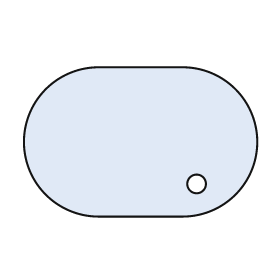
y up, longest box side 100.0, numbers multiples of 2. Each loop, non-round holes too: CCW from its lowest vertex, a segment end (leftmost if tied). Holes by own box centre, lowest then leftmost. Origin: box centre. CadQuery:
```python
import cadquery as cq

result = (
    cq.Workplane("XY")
    .moveTo(-18.0, -32.0)
    .lineTo(18.0, -32.0)
    .threePointArc((50.0, 0.0), (18.0, 32.0))
    .lineTo(-18.0, 32.0)
    .threePointArc((-50.0, 0.0), (-18.0, -32.0))
    .close()
    .moveTo(24.0, -18.0)
    .circle(4.0)
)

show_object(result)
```